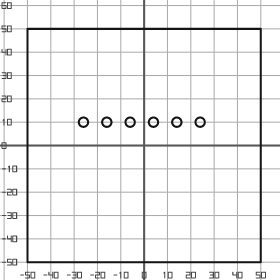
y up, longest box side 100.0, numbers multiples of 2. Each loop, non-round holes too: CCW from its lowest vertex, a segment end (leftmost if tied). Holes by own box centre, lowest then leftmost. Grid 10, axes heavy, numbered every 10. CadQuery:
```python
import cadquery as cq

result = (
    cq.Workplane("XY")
    .moveTo(-50.0, -50.0)
    .lineTo(50.0, -50.0)
    .lineTo(50.0, 50.0)
    .lineTo(-50.0, 50.0)
    .close()
    .moveTo(-26.0, 10.0)
    .circle(2.0)
    .moveTo(-16.0, 10.0)
    .circle(2.0)
    .moveTo(-6.0, 10.0)
    .circle(2.0)
    .moveTo(4.0, 10.0)
    .circle(2.0)
    .moveTo(14.0, 10.0)
    .circle(2.0)
    .moveTo(24.0, 10.0)
    .circle(2.0)
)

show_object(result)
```